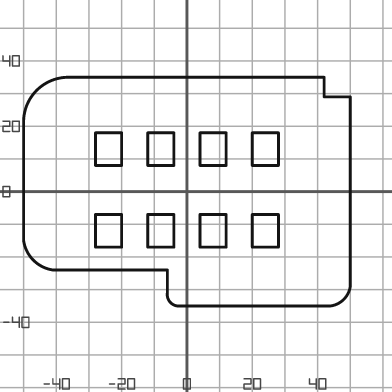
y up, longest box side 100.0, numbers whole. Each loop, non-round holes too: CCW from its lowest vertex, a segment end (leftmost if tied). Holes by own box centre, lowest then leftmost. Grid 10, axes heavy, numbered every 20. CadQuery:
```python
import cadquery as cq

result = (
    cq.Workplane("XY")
    .moveTo(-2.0, -35.0)
    .lineTo(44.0, -35.0)
    .threePointArc((48.0, -33.0), (50.0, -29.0))
    .lineTo(50.0, 29.0)
    .lineTo(42.0, 29.0)
    .lineTo(42.0, 35.0)
    .lineTo(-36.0, 35.0)
    .threePointArc((-46.0, 31.0), (-50.0, 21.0))
    .lineTo(-50.0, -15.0)
    .threePointArc((-47.0, -21.0), (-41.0, -24.0))
    .lineTo(-6.0, -24.0)
    .lineTo(-6.0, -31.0)
    .threePointArc((-5.0, -34.0), (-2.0, -35.0))
    .close()
    .moveTo(-28.0, -17.0)
    .lineTo(-20.0, -17.0)
    .lineTo(-20.0, -7.0)
    .lineTo(-28.0, -7.0)
    .close()
    .moveTo(-12.0, -17.0)
    .lineTo(-4.0, -17.0)
    .lineTo(-4.0, -7.0)
    .lineTo(-12.0, -7.0)
    .close()
    .moveTo(4.0, -17.0)
    .lineTo(12.0, -17.0)
    .lineTo(12.0, -7.0)
    .lineTo(4.0, -7.0)
    .close()
    .moveTo(20.0, -17.0)
    .lineTo(28.0, -17.0)
    .lineTo(28.0, -7.0)
    .lineTo(20.0, -7.0)
    .close()
    .moveTo(-28.0, 8.0)
    .lineTo(-20.0, 8.0)
    .lineTo(-20.0, 18.0)
    .lineTo(-28.0, 18.0)
    .close()
    .moveTo(-12.0, 8.0)
    .lineTo(-4.0, 8.0)
    .lineTo(-4.0, 18.0)
    .lineTo(-12.0, 18.0)
    .close()
    .moveTo(4.0, 8.0)
    .lineTo(12.0, 8.0)
    .lineTo(12.0, 18.0)
    .lineTo(4.0, 18.0)
    .close()
    .moveTo(20.0, 8.0)
    .lineTo(28.0, 8.0)
    .lineTo(28.0, 18.0)
    .lineTo(20.0, 18.0)
    .close()
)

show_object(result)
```